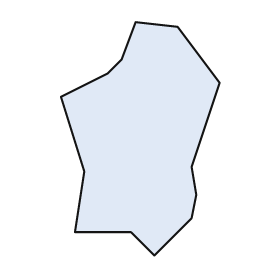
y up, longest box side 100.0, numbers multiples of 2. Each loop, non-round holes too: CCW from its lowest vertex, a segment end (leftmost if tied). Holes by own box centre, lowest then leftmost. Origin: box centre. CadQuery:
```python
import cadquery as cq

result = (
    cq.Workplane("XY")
    .moveTo(6.0, -50.0)
    .lineTo(22.0, -34.0)
    .lineTo(24.0, -24.0)
    .lineTo(22.0, -12.0)
    .lineTo(34.0, 24.0)
    .lineTo(16.0, 48.0)
    .lineTo(-2.0, 50.0)
    .lineTo(-8.0, 34.0)
    .lineTo(-14.0, 28.0)
    .lineTo(-34.0, 18.0)
    .lineTo(-24.0, -14.0)
    .lineTo(-28.0, -40.0)
    .lineTo(-4.0, -40.0)
    .close()
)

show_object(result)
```